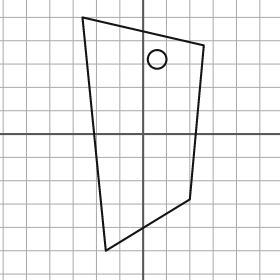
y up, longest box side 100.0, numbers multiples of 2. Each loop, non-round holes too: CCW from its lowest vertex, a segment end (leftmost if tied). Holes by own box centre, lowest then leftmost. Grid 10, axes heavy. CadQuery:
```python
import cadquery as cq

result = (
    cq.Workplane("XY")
    .moveTo(-16.0, -50.0)
    .lineTo(20.0, -28.0)
    .lineTo(26.0, 38.0)
    .lineTo(-26.0, 50.0)
    .close()
    .moveTo(6.0, 32.0)
    .circle(4.0)
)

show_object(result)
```